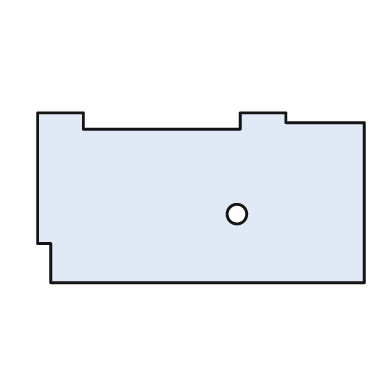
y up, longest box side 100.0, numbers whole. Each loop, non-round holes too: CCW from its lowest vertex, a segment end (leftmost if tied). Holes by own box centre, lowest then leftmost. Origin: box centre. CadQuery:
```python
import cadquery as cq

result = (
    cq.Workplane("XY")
    .moveTo(-46.0, -26.0)
    .lineTo(50.0, -26.0)
    .lineTo(50.0, 23.0)
    .lineTo(26.0, 23.0)
    .lineTo(26.0, 26.0)
    .lineTo(12.0, 26.0)
    .lineTo(12.0, 21.0)
    .lineTo(-36.0, 21.0)
    .lineTo(-36.0, 26.0)
    .lineTo(-50.0, 26.0)
    .lineTo(-50.0, -14.0)
    .lineTo(-46.0, -14.0)
    .close()
    .moveTo(11.0, -5.0)
    .circle(3.0)
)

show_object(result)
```